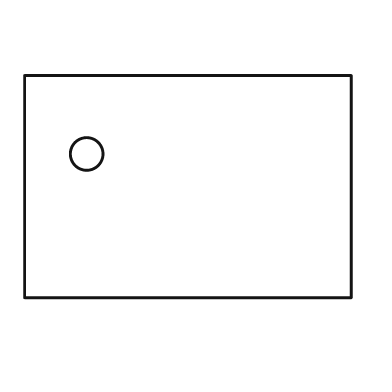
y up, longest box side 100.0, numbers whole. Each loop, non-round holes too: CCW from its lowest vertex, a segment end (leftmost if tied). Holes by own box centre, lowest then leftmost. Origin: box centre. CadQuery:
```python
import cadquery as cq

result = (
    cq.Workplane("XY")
    .moveTo(-50.0, -34.0)
    .lineTo(50.0, -34.0)
    .lineTo(50.0, 34.0)
    .lineTo(-50.0, 34.0)
    .close()
    .moveTo(-31.0, 10.0)
    .circle(5.0)
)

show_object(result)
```